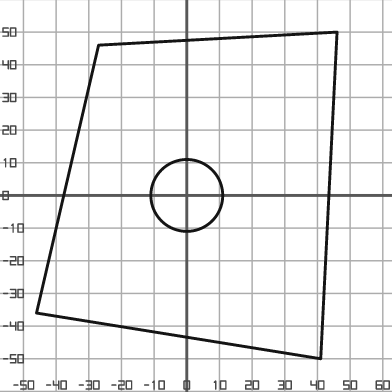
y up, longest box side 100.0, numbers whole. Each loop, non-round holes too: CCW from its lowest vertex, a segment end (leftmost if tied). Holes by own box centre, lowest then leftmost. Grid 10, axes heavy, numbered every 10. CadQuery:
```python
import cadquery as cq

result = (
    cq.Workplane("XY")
    .moveTo(41.0, -50.0)
    .lineTo(46.0, 50.0)
    .lineTo(-27.0, 46.0)
    .lineTo(-46.0, -36.0)
    .close()
    .moveTo(0.0, 0.0)
    .circle(11.0)
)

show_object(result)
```